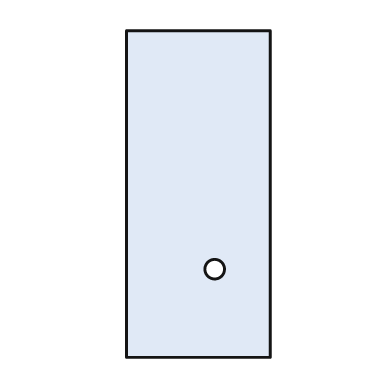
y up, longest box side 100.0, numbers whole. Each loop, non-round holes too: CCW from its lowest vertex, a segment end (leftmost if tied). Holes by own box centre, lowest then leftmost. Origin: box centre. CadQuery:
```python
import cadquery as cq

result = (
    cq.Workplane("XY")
    .moveTo(-22.0, -50.0)
    .lineTo(22.0, -50.0)
    .lineTo(22.0, 50.0)
    .lineTo(-22.0, 50.0)
    .close()
    .moveTo(5.0, -23.0)
    .circle(3.0)
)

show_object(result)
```